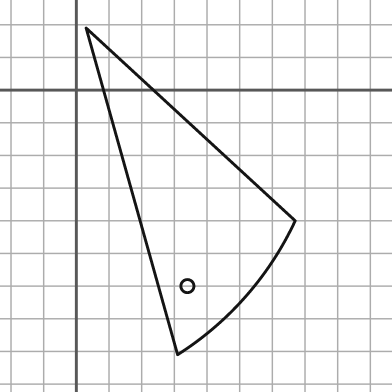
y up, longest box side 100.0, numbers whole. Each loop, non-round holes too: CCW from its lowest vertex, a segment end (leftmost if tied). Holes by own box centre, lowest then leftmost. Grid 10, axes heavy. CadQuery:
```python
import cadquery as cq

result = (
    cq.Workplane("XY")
    .moveTo(31.0, -81.0)
    .threePointArc((52.0, -63.0), (67.0, -40.0))
    .lineTo(3.0, 19.0)
    .close()
    .moveTo(34.0, -60.0)
    .circle(2.0)
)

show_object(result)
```